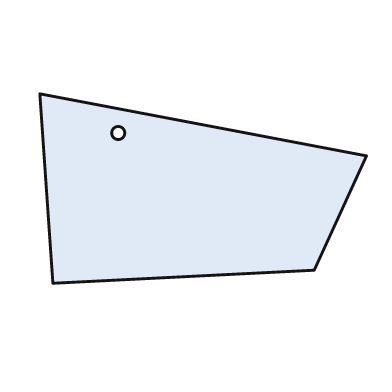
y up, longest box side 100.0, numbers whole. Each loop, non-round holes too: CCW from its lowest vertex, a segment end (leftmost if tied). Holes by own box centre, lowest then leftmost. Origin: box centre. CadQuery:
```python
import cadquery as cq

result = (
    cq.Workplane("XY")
    .moveTo(-46.0, -29.0)
    .lineTo(34.0, -25.0)
    .lineTo(50.0, 10.0)
    .lineTo(-50.0, 29.0)
    .close()
    .moveTo(-26.0, 17.0)
    .circle(2.0)
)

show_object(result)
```